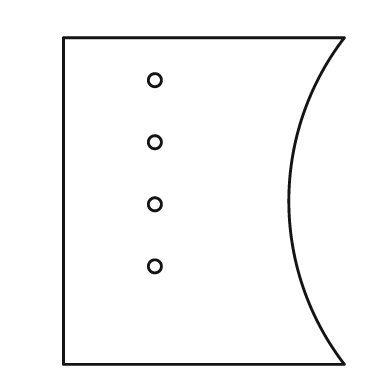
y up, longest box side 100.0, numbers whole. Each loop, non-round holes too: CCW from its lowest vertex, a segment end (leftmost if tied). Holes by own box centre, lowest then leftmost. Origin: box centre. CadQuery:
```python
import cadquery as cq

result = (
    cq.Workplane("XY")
    .moveTo(-43.0, -50.0)
    .lineTo(43.0, -50.0)
    .threePointArc((26.0, 0.0), (43.0, 50.0))
    .lineTo(-43.0, 50.0)
    .close()
    .moveTo(-15.0, -20.0)
    .circle(2.0)
    .moveTo(-15.0, -1.0)
    .circle(2.0)
    .moveTo(-15.0, 18.0)
    .circle(2.0)
    .moveTo(-15.0, 37.0)
    .circle(2.0)
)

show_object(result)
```